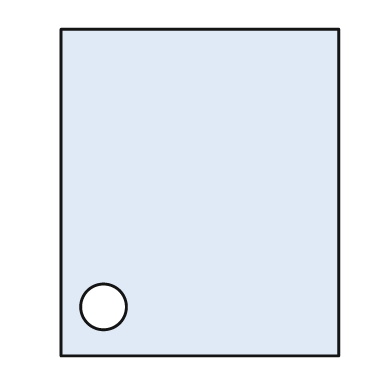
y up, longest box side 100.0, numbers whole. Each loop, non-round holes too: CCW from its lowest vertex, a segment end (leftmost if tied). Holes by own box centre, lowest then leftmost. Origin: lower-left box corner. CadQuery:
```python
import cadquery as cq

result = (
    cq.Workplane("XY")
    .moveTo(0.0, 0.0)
    .lineTo(85.0, 0.0)
    .lineTo(85.0, 100.0)
    .lineTo(0.0, 100.0)
    .close()
    .moveTo(13.0, 15.0)
    .circle(7.0)
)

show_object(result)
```